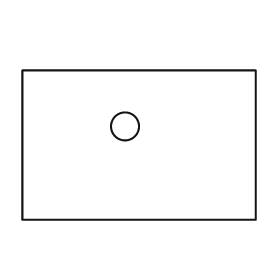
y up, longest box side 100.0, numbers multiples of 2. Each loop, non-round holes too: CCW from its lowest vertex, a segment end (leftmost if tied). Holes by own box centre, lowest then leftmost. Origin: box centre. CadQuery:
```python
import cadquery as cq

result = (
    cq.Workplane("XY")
    .moveTo(-50.0, -32.0)
    .lineTo(50.0, -32.0)
    .lineTo(50.0, 32.0)
    .lineTo(-50.0, 32.0)
    .close()
    .moveTo(-6.0, 8.0)
    .circle(6.0)
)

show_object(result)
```